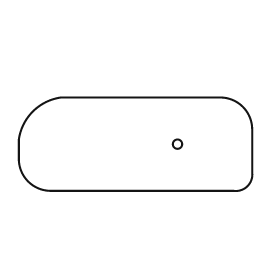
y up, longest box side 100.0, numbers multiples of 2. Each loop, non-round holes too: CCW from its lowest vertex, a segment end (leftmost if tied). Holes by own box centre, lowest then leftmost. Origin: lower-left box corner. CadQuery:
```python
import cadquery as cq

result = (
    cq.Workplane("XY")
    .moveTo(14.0, 0.0)
    .lineTo(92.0, 0.0)
    .threePointArc((98.0, 2.0), (100.0, 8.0))
    .lineTo(100.0, 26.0)
    .threePointArc((96.0, 36.0), (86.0, 40.0))
    .lineTo(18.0, 40.0)
    .threePointArc((6.0, 34.0), (0.0, 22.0))
    .lineTo(0.0, 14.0)
    .threePointArc((4.0, 4.0), (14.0, 0.0))
    .close()
    .moveTo(68.0, 20.0)
    .circle(2.0)
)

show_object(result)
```